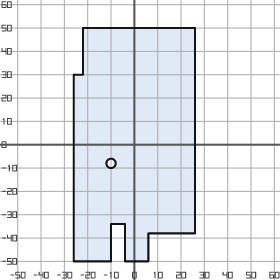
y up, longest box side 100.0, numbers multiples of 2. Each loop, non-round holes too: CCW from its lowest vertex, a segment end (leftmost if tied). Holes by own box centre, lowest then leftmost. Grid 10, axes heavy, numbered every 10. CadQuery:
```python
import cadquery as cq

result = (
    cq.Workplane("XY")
    .moveTo(-26.0, -50.0)
    .lineTo(-10.0, -50.0)
    .lineTo(-10.0, -34.0)
    .lineTo(-4.0, -34.0)
    .lineTo(-4.0, -50.0)
    .lineTo(6.0, -50.0)
    .lineTo(6.0, -38.0)
    .lineTo(26.0, -38.0)
    .lineTo(26.0, 50.0)
    .lineTo(-22.0, 50.0)
    .lineTo(-22.0, 30.0)
    .lineTo(-26.0, 30.0)
    .close()
    .moveTo(-10.0, -8.0)
    .circle(2.0)
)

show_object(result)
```